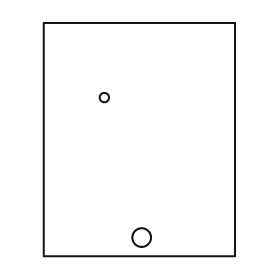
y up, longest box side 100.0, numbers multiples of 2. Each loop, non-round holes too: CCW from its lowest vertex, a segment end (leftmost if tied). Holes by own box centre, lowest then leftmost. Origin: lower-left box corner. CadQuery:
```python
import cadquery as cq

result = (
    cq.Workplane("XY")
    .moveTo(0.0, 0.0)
    .lineTo(82.0, 0.0)
    .lineTo(82.0, 100.0)
    .lineTo(0.0, 100.0)
    .close()
    .moveTo(42.0, 8.0)
    .circle(4.0)
    .moveTo(26.0, 68.0)
    .circle(2.0)
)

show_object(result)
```